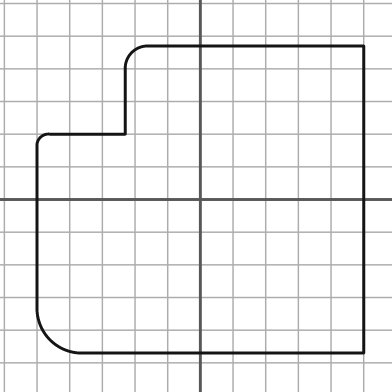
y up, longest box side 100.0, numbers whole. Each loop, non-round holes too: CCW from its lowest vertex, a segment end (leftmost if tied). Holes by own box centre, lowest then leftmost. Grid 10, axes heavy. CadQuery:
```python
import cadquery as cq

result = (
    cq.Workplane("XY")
    .moveTo(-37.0, -47.0)
    .lineTo(50.0, -47.0)
    .lineTo(50.0, 47.0)
    .lineTo(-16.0, 47.0)
    .threePointArc((-21.0, 45.0), (-23.0, 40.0))
    .lineTo(-23.0, 20.0)
    .lineTo(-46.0, 20.0)
    .threePointArc((-49.0, 19.0), (-50.0, 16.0))
    .lineTo(-50.0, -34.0)
    .threePointArc((-46.0, -43.0), (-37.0, -47.0))
    .close()
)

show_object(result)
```